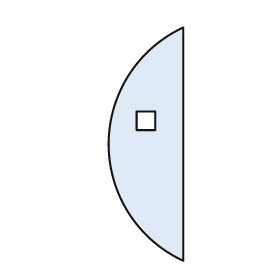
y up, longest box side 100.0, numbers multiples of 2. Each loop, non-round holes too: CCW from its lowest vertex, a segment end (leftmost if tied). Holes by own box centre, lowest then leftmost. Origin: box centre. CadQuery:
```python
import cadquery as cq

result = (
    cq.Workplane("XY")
    .moveTo(16.0, -50.0)
    .lineTo(16.0, 50.0)
    .threePointArc((-16.0, 0.0), (16.0, -50.0))
    .close()
    .moveTo(-4.0, 6.0)
    .lineTo(4.0, 6.0)
    .lineTo(4.0, 14.0)
    .lineTo(-4.0, 14.0)
    .close()
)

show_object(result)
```